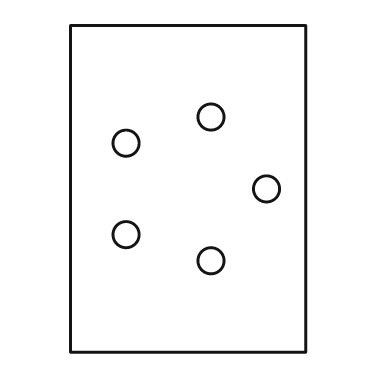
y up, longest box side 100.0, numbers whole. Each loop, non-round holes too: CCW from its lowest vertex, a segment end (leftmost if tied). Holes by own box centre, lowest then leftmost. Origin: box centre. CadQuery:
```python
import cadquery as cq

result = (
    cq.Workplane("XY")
    .moveTo(-36.0, -50.0)
    .lineTo(36.0, -50.0)
    .lineTo(36.0, 50.0)
    .lineTo(-36.0, 50.0)
    .close()
    .moveTo(7.0, -22.0)
    .circle(4.0)
    .moveTo(-19.0, -14.0)
    .circle(4.0)
    .moveTo(24.0, 0.0)
    .circle(4.0)
    .moveTo(-19.0, 14.0)
    .circle(4.0)
    .moveTo(7.0, 22.0)
    .circle(4.0)
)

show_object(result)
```